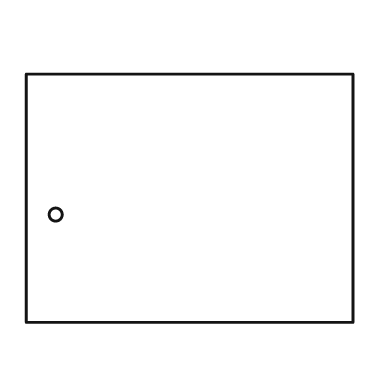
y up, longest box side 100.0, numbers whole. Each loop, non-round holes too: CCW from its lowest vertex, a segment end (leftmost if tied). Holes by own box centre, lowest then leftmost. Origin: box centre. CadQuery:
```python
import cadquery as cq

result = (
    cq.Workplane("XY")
    .moveTo(-50.0, -38.0)
    .lineTo(50.0, -38.0)
    .lineTo(50.0, 38.0)
    .lineTo(-50.0, 38.0)
    .close()
    .moveTo(-41.0, -5.0)
    .circle(2.0)
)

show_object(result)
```